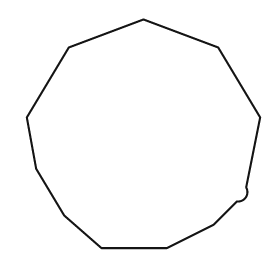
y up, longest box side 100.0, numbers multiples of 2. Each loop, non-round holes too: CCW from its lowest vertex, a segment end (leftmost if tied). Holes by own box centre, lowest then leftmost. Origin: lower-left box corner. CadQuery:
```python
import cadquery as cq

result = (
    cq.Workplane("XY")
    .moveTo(32.0, 0.0)
    .lineTo(60.0, 0.0)
    .lineTo(80.0, 10.0)
    .lineTo(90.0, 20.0)
    .threePointArc((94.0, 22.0), (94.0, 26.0))
    .lineTo(100.0, 56.0)
    .lineTo(82.0, 86.0)
    .lineTo(50.0, 98.0)
    .lineTo(18.0, 86.0)
    .lineTo(0.0, 56.0)
    .lineTo(4.0, 34.0)
    .lineTo(16.0, 14.0)
    .close()
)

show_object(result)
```